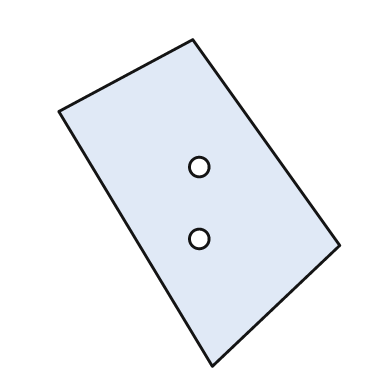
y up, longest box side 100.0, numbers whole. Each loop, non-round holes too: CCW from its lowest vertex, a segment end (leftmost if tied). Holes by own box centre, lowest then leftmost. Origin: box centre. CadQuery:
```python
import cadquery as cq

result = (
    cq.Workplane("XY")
    .moveTo(4.0, -50.0)
    .lineTo(43.0, -13.0)
    .lineTo(-2.0, 50.0)
    .lineTo(-43.0, 28.0)
    .close()
    .moveTo(0.0, -11.0)
    .circle(3.0)
    .moveTo(0.0, 11.0)
    .circle(3.0)
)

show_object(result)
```